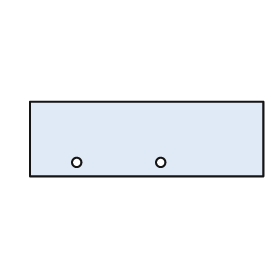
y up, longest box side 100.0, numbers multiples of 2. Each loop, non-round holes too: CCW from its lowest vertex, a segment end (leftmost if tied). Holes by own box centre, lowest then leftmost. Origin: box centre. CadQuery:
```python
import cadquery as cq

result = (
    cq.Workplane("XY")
    .moveTo(-50.0, -16.0)
    .lineTo(50.0, -16.0)
    .lineTo(50.0, 16.0)
    .lineTo(-50.0, 16.0)
    .close()
    .moveTo(-30.0, -10.0)
    .circle(2.0)
    .moveTo(6.0, -10.0)
    .circle(2.0)
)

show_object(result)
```